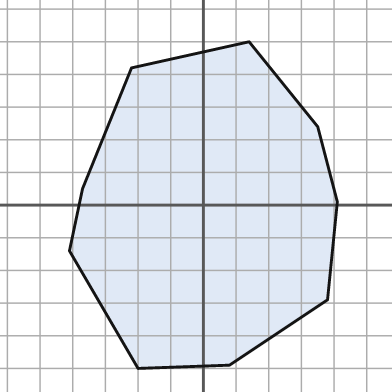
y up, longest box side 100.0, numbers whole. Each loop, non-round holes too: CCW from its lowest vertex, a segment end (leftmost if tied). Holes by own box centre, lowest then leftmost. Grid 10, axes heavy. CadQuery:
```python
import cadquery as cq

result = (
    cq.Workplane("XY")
    .moveTo(-20.0, -50.0)
    .lineTo(8.0, -49.0)
    .lineTo(38.0, -29.0)
    .lineTo(41.0, 1.0)
    .lineTo(35.0, 24.0)
    .lineTo(14.0, 50.0)
    .lineTo(-22.0, 42.0)
    .lineTo(-37.0, 5.0)
    .lineTo(-41.0, -14.0)
    .close()
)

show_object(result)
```